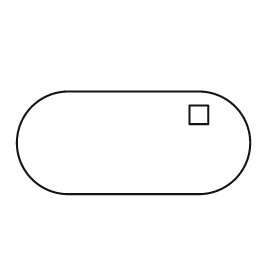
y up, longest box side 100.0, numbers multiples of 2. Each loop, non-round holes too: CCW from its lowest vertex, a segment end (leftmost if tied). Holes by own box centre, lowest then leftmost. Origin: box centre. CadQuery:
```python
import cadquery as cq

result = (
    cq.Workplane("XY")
    .moveTo(-28.0, -22.0)
    .lineTo(28.0, -22.0)
    .threePointArc((50.0, 0.0), (28.0, 22.0))
    .lineTo(-28.0, 22.0)
    .threePointArc((-50.0, 0.0), (-28.0, -22.0))
    .close()
    .moveTo(24.0, 8.0)
    .lineTo(32.0, 8.0)
    .lineTo(32.0, 16.0)
    .lineTo(24.0, 16.0)
    .close()
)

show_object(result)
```